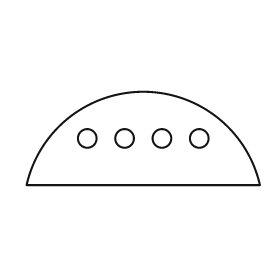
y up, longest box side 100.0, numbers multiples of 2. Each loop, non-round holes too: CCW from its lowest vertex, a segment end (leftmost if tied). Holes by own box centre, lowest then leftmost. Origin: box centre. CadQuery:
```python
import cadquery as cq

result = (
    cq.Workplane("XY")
    .moveTo(-50.0, -20.0)
    .lineTo(50.0, -20.0)
    .threePointArc((0.0, 20.0), (-50.0, -20.0))
    .close()
    .moveTo(-24.0, 0.0)
    .circle(4.0)
    .moveTo(-8.0, 0.0)
    .circle(4.0)
    .moveTo(8.0, 0.0)
    .circle(4.0)
    .moveTo(24.0, 0.0)
    .circle(4.0)
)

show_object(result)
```